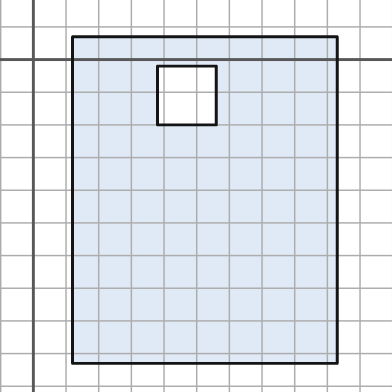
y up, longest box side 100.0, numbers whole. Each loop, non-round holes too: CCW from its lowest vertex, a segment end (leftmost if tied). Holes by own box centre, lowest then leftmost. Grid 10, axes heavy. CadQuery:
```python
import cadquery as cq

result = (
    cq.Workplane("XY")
    .moveTo(12.0, -93.0)
    .lineTo(93.0, -93.0)
    .lineTo(93.0, 7.0)
    .lineTo(12.0, 7.0)
    .close()
    .moveTo(38.0, -20.0)
    .lineTo(56.0, -20.0)
    .lineTo(56.0, -2.0)
    .lineTo(38.0, -2.0)
    .close()
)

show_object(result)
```